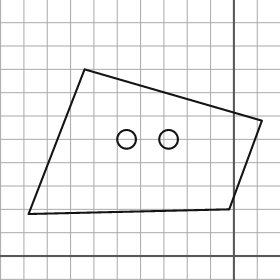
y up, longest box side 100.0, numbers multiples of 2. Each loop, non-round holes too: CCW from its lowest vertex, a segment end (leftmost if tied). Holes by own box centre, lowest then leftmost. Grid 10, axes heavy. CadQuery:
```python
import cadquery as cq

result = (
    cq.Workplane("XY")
    .moveTo(-88.0, 18.0)
    .lineTo(-2.0, 20.0)
    .lineTo(12.0, 58.0)
    .lineTo(-64.0, 80.0)
    .close()
    .moveTo(-46.0, 50.0)
    .circle(4.0)
    .moveTo(-28.0, 50.0)
    .circle(4.0)
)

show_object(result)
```